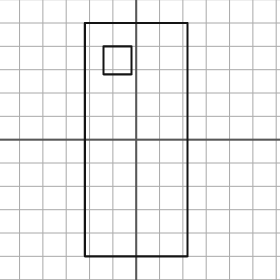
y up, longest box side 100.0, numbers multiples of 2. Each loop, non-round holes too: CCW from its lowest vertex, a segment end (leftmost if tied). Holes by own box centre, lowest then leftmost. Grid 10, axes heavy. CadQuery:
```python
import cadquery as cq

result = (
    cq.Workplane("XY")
    .moveTo(-22.0, -50.0)
    .lineTo(22.0, -50.0)
    .lineTo(22.0, 50.0)
    .lineTo(-22.0, 50.0)
    .close()
    .moveTo(-14.0, 28.0)
    .lineTo(-2.0, 28.0)
    .lineTo(-2.0, 40.0)
    .lineTo(-14.0, 40.0)
    .close()
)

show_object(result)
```